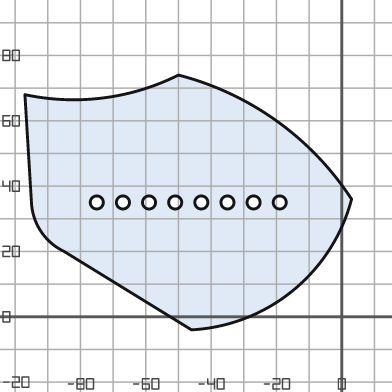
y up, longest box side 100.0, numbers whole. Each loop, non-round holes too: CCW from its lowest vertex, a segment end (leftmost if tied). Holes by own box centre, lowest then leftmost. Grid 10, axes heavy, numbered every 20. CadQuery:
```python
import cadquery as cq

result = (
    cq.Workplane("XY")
    .moveTo(-46.0, -4.0)
    .threePointArc((-15.0, 8.0), (3.0, 36.0))
    .threePointArc((-20.0, 60.0), (-50.0, 74.0))
    .threePointArc((-73.0, 67.0), (-97.0, 68.0))
    .lineTo(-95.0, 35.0)
    .threePointArc((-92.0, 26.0), (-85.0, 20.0))
    .close()
    .moveTo(-75.0, 35.0)
    .circle(2.0)
    .moveTo(-67.0, 35.0)
    .circle(2.0)
    .moveTo(-59.0, 35.0)
    .circle(2.0)
    .moveTo(-51.0, 35.0)
    .circle(2.0)
    .moveTo(-43.0, 35.0)
    .circle(2.0)
    .moveTo(-35.0, 35.0)
    .circle(2.0)
    .moveTo(-27.0, 35.0)
    .circle(2.0)
    .moveTo(-19.0, 35.0)
    .circle(2.0)
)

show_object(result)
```